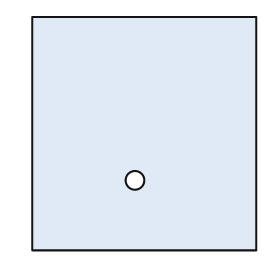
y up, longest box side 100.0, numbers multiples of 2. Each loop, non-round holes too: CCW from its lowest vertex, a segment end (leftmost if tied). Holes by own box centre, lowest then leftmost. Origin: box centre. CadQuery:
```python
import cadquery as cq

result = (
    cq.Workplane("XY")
    .moveTo(-48.0, -50.0)
    .lineTo(48.0, -50.0)
    .lineTo(48.0, 50.0)
    .lineTo(-48.0, 50.0)
    .close()
    .moveTo(-4.0, -20.0)
    .circle(4.0)
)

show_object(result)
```